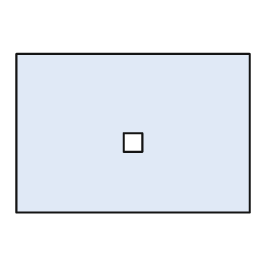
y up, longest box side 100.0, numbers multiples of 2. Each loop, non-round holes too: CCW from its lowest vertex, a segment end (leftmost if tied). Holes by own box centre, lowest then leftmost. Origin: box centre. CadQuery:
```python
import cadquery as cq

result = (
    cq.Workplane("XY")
    .moveTo(-50.0, -34.0)
    .lineTo(50.0, -34.0)
    .lineTo(50.0, 34.0)
    .lineTo(-50.0, 34.0)
    .close()
    .moveTo(-4.0, -8.0)
    .lineTo(4.0, -8.0)
    .lineTo(4.0, 0.0)
    .lineTo(-4.0, 0.0)
    .close()
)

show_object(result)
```